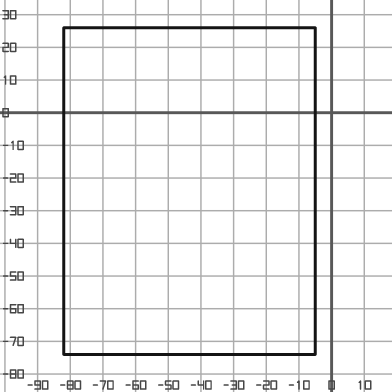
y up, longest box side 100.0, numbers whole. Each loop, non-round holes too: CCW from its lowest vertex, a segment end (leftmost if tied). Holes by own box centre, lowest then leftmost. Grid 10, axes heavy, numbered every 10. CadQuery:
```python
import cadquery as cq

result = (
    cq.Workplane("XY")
    .moveTo(-82.0, -74.0)
    .lineTo(-5.0, -74.0)
    .lineTo(-5.0, 26.0)
    .lineTo(-82.0, 26.0)
    .close()
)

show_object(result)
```